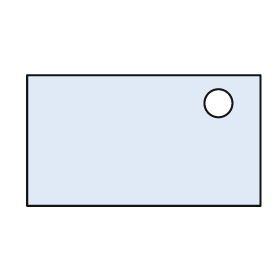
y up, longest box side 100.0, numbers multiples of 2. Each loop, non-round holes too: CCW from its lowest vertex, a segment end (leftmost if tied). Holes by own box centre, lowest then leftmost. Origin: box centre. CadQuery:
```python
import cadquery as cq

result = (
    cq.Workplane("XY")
    .moveTo(-50.0, -28.0)
    .lineTo(50.0, -28.0)
    .lineTo(50.0, 28.0)
    .lineTo(-50.0, 28.0)
    .close()
    .moveTo(32.0, 16.0)
    .circle(6.0)
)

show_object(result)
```